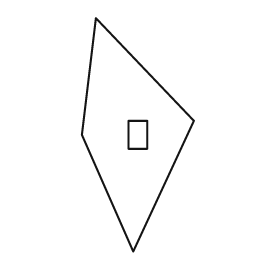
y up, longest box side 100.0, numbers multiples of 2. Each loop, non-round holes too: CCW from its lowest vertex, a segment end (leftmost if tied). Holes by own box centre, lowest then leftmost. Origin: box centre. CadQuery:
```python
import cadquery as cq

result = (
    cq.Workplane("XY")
    .moveTo(-2.0, -50.0)
    .lineTo(24.0, 6.0)
    .lineTo(-18.0, 50.0)
    .lineTo(-24.0, 0.0)
    .close()
    .moveTo(-4.0, -6.0)
    .lineTo(4.0, -6.0)
    .lineTo(4.0, 6.0)
    .lineTo(-4.0, 6.0)
    .close()
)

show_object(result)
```